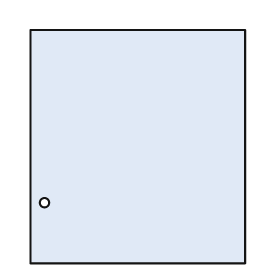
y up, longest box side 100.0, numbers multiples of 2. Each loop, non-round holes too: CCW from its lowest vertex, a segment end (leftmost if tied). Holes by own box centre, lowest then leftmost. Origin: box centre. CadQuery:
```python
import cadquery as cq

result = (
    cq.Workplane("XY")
    .moveTo(-46.0, -50.0)
    .lineTo(46.0, -50.0)
    .lineTo(46.0, 50.0)
    .lineTo(-46.0, 50.0)
    .close()
    .moveTo(-40.0, -24.0)
    .circle(2.0)
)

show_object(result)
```